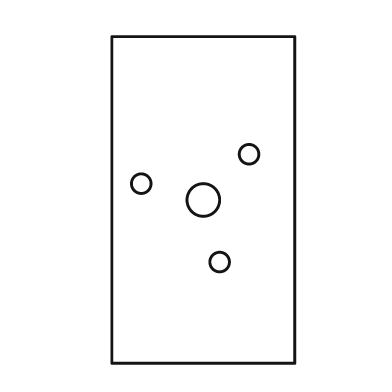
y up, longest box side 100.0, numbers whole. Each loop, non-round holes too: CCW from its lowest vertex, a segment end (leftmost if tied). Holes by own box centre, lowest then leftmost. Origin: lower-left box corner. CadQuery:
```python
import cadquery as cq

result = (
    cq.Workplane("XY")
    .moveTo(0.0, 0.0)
    .lineTo(56.0, 0.0)
    .lineTo(56.0, 100.0)
    .lineTo(0.0, 100.0)
    .close()
    .moveTo(33.0, 31.0)
    .circle(3.0)
    .moveTo(28.0, 50.0)
    .circle(5.0)
    .moveTo(9.0, 55.0)
    .circle(3.0)
    .moveTo(42.0, 64.0)
    .circle(3.0)
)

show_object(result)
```